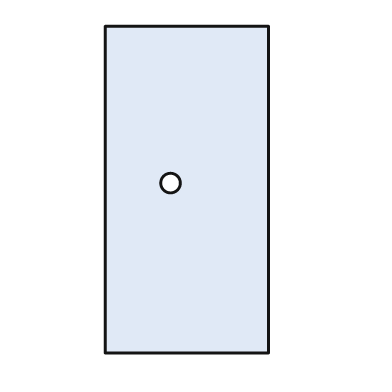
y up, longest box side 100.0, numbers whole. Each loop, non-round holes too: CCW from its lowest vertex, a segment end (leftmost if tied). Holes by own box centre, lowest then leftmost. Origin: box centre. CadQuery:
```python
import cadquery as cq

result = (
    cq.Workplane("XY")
    .moveTo(-25.0, -50.0)
    .lineTo(25.0, -50.0)
    .lineTo(25.0, 50.0)
    .lineTo(-25.0, 50.0)
    .close()
    .moveTo(-5.0, 2.0)
    .circle(3.0)
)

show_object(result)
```